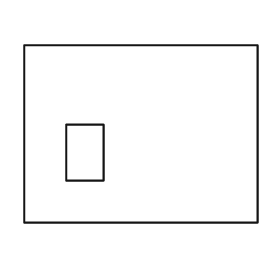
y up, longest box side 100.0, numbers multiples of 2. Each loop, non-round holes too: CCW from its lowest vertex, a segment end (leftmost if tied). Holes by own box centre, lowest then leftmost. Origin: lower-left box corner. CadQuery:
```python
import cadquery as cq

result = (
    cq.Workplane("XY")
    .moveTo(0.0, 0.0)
    .lineTo(100.0, 0.0)
    .lineTo(100.0, 76.0)
    .lineTo(0.0, 76.0)
    .close()
    .moveTo(18.0, 18.0)
    .lineTo(34.0, 18.0)
    .lineTo(34.0, 42.0)
    .lineTo(18.0, 42.0)
    .close()
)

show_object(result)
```